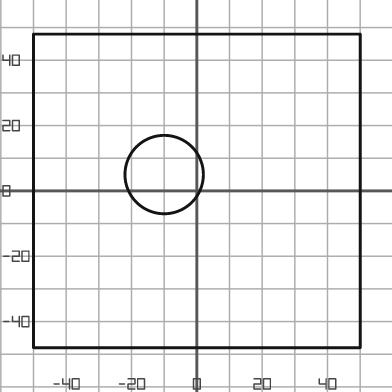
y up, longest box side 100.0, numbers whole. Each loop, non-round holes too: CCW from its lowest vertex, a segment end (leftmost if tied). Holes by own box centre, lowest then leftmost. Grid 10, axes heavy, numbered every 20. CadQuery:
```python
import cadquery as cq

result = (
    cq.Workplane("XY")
    .moveTo(-50.0, -48.0)
    .lineTo(50.0, -48.0)
    .lineTo(50.0, 48.0)
    .lineTo(-50.0, 48.0)
    .close()
    .moveTo(-10.0, 5.0)
    .circle(12.0)
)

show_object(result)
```